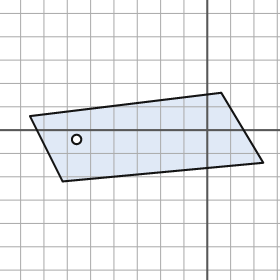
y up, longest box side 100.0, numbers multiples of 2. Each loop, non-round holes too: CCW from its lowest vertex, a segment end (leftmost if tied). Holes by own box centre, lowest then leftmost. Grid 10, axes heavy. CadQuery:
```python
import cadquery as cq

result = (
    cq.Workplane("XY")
    .moveTo(-62.0, -22.0)
    .lineTo(24.0, -14.0)
    .lineTo(6.0, 16.0)
    .lineTo(-76.0, 6.0)
    .close()
    .moveTo(-56.0, -4.0)
    .circle(2.0)
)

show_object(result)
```